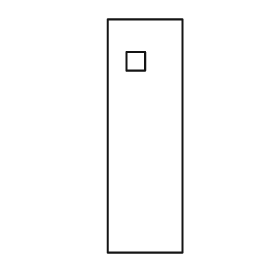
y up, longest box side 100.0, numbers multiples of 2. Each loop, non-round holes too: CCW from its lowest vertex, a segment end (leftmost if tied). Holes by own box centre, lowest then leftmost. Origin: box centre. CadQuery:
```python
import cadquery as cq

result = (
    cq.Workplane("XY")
    .moveTo(-16.0, -50.0)
    .lineTo(16.0, -50.0)
    .lineTo(16.0, 50.0)
    .lineTo(-16.0, 50.0)
    .close()
    .moveTo(-8.0, 28.0)
    .lineTo(0.0, 28.0)
    .lineTo(0.0, 36.0)
    .lineTo(-8.0, 36.0)
    .close()
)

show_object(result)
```